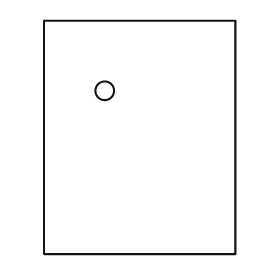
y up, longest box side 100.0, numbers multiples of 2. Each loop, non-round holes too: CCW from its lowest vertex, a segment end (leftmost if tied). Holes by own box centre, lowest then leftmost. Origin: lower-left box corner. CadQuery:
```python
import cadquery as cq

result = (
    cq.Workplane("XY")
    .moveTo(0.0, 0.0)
    .lineTo(82.0, 0.0)
    .lineTo(82.0, 100.0)
    .lineTo(0.0, 100.0)
    .close()
    .moveTo(26.0, 70.0)
    .circle(4.0)
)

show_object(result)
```